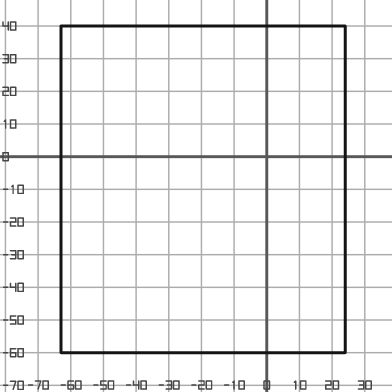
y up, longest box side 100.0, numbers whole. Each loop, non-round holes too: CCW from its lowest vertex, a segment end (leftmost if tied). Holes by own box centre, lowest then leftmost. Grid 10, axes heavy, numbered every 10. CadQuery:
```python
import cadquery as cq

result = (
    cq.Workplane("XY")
    .moveTo(-63.0, -60.0)
    .lineTo(24.0, -60.0)
    .lineTo(24.0, 40.0)
    .lineTo(-63.0, 40.0)
    .close()
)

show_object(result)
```